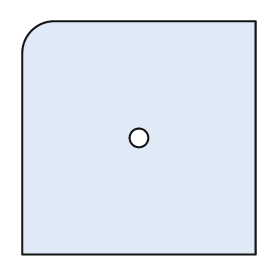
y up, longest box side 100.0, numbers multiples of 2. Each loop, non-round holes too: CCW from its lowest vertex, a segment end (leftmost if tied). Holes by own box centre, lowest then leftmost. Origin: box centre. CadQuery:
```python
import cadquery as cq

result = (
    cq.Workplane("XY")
    .moveTo(-50.0, -50.0)
    .lineTo(50.0, -50.0)
    .lineTo(50.0, 50.0)
    .lineTo(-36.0, 50.0)
    .threePointArc((-46.0, 46.0), (-50.0, 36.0))
    .close()
    .moveTo(0.0, 0.0)
    .circle(4.0)
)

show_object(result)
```